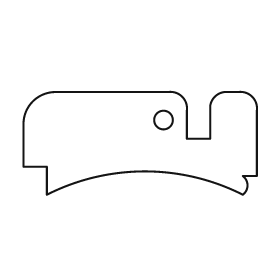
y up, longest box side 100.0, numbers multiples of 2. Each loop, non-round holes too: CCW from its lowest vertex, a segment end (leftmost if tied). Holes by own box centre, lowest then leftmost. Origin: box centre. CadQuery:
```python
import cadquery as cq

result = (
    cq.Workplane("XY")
    .moveTo(-40.0, -22.0)
    .threePointArc((2.0, -12.0), (44.0, -22.0))
    .threePointArc((46.0, -18.0), (44.0, -14.0))
    .lineTo(50.0, -14.0)
    .lineTo(50.0, 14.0)
    .threePointArc((48.0, 20.0), (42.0, 22.0))
    .lineTo(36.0, 22.0)
    .threePointArc((32.0, 20.0), (30.0, 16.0))
    .lineTo(30.0, 2.0)
    .lineTo(20.0, 2.0)
    .lineTo(20.0, 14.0)
    .threePointArc((18.0, 20.0), (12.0, 22.0))
    .lineTo(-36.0, 22.0)
    .threePointArc((-46.0, 18.0), (-50.0, 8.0))
    .lineTo(-50.0, -10.0)
    .lineTo(-40.0, -10.0)
    .close()
    .moveTo(10.0, 10.0)
    .circle(4.0)
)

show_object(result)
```